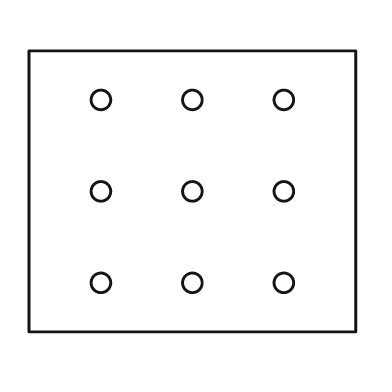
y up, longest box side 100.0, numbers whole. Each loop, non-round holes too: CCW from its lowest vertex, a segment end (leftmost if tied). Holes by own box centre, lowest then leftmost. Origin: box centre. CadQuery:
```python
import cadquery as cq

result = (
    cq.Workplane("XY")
    .moveTo(-50.0, -43.0)
    .lineTo(50.0, -43.0)
    .lineTo(50.0, 43.0)
    .lineTo(-50.0, 43.0)
    .close()
    .moveTo(-28.0, -28.0)
    .circle(3.0)
    .moveTo(0.0, -28.0)
    .circle(3.0)
    .moveTo(28.0, -28.0)
    .circle(3.0)
    .moveTo(-28.0, 0.0)
    .circle(3.0)
    .moveTo(0.0, 0.0)
    .circle(3.0)
    .moveTo(28.0, 0.0)
    .circle(3.0)
    .moveTo(-28.0, 28.0)
    .circle(3.0)
    .moveTo(0.0, 28.0)
    .circle(3.0)
    .moveTo(28.0, 28.0)
    .circle(3.0)
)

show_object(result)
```